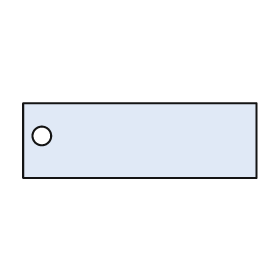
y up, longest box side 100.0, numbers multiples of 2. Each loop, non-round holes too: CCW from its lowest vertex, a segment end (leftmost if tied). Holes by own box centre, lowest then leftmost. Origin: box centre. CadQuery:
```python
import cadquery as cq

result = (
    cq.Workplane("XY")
    .moveTo(-50.0, -16.0)
    .lineTo(50.0, -16.0)
    .lineTo(50.0, 16.0)
    .lineTo(-50.0, 16.0)
    .close()
    .moveTo(-42.0, 2.0)
    .circle(4.0)
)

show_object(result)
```